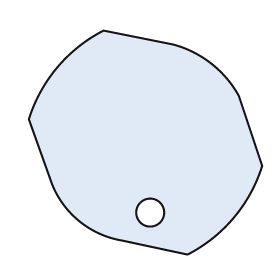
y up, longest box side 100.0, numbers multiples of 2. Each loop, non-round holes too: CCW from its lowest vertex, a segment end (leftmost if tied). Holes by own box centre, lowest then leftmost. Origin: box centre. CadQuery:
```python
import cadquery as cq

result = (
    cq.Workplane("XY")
    .moveTo(18.0, -48.0)
    .threePointArc((38.0, -32.0), (50.0, -10.0))
    .lineTo(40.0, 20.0)
    .threePointArc((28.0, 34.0), (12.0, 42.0))
    .lineTo(-18.0, 48.0)
    .threePointArc((-38.0, 32.0), (-50.0, 10.0))
    .lineTo(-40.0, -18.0)
    .threePointArc((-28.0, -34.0), (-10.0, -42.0))
    .close()
    .moveTo(2.0, -30.0)
    .circle(6.0)
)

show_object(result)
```